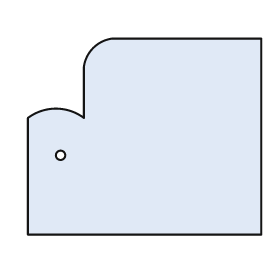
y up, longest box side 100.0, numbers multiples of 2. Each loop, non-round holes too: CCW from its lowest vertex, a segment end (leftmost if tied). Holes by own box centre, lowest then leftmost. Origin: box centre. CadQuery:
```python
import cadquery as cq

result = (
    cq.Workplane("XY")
    .moveTo(-50.0, -42.0)
    .lineTo(50.0, -42.0)
    .lineTo(50.0, 42.0)
    .lineTo(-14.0, 42.0)
    .threePointArc((-22.0, 38.0), (-26.0, 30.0))
    .lineTo(-26.0, 8.0)
    .threePointArc((-38.0, 12.0), (-50.0, 8.0))
    .close()
    .moveTo(-36.0, -8.0)
    .circle(2.0)
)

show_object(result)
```